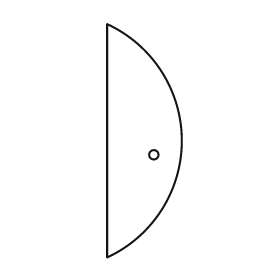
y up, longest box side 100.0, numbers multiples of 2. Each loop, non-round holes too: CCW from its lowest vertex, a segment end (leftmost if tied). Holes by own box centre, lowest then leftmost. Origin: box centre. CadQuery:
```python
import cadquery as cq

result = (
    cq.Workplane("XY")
    .moveTo(-16.0, -50.0)
    .threePointArc((16.0, 0.0), (-16.0, 50.0))
    .close()
    .moveTo(4.0, -6.0)
    .circle(2.0)
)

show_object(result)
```